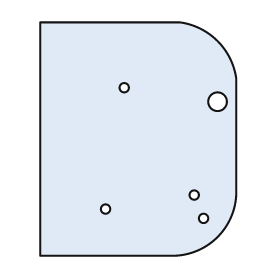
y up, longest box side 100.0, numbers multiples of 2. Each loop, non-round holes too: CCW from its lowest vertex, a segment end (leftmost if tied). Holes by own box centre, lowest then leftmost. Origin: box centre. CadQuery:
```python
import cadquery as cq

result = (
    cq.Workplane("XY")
    .moveTo(-42.0, -50.0)
    .lineTo(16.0, -50.0)
    .threePointArc((34.0, -42.0), (42.0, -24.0))
    .lineTo(42.0, 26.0)
    .threePointArc((34.0, 42.0), (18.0, 50.0))
    .lineTo(-42.0, 50.0)
    .close()
    .moveTo(28.0, -34.0)
    .circle(2.0)
    .moveTo(-14.0, -30.0)
    .circle(2.0)
    .moveTo(24.0, -24.0)
    .circle(2.0)
    .moveTo(34.0, 16.0)
    .circle(4.0)
    .moveTo(-6.0, 22.0)
    .circle(2.0)
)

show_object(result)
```